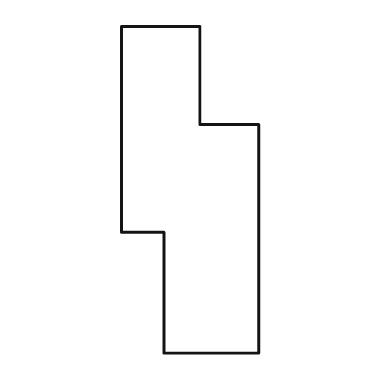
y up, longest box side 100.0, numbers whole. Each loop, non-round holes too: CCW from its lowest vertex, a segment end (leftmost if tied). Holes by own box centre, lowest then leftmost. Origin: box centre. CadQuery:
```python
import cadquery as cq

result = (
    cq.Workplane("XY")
    .moveTo(-8.0, -50.0)
    .lineTo(21.0, -50.0)
    .lineTo(21.0, 20.0)
    .lineTo(3.0, 20.0)
    .lineTo(3.0, 50.0)
    .lineTo(-21.0, 50.0)
    .lineTo(-21.0, -13.0)
    .lineTo(-8.0, -13.0)
    .close()
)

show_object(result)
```